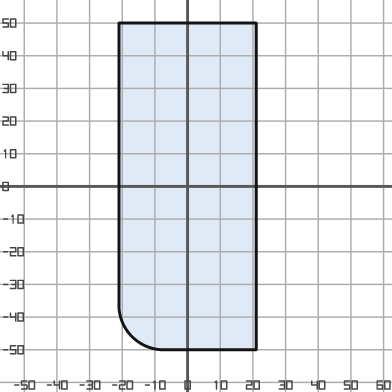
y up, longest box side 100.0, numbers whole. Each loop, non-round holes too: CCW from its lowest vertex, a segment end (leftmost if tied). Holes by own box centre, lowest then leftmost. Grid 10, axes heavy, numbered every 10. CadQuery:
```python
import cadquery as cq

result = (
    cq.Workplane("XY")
    .moveTo(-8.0, -50.0)
    .lineTo(21.0, -50.0)
    .lineTo(21.0, 50.0)
    .lineTo(-21.0, 50.0)
    .lineTo(-21.0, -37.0)
    .threePointArc((-17.0, -46.0), (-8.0, -50.0))
    .close()
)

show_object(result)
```